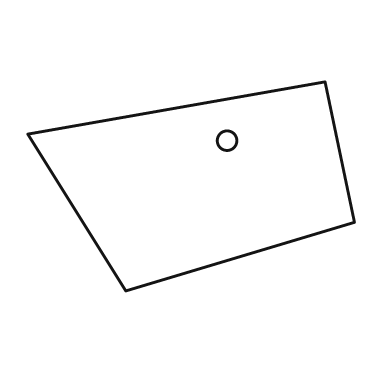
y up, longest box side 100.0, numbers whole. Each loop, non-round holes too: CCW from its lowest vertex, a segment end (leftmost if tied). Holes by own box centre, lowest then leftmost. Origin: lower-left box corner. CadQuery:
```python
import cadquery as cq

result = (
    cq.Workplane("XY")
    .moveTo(30.0, 0.0)
    .lineTo(100.0, 21.0)
    .lineTo(91.0, 64.0)
    .lineTo(0.0, 48.0)
    .close()
    .moveTo(61.0, 46.0)
    .circle(3.0)
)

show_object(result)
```